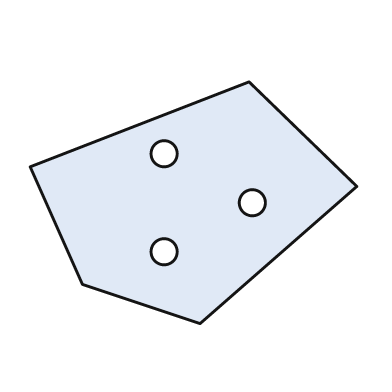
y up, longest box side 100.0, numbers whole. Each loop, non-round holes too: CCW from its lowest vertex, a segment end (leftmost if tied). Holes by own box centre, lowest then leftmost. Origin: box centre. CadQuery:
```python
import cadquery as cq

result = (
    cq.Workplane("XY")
    .moveTo(2.0, -37.0)
    .lineTo(50.0, 5.0)
    .lineTo(17.0, 37.0)
    .lineTo(-50.0, 11.0)
    .lineTo(-34.0, -25.0)
    .close()
    .moveTo(-9.0, -15.0)
    .circle(4.0)
    .moveTo(18.0, 0.0)
    .circle(4.0)
    .moveTo(-9.0, 15.0)
    .circle(4.0)
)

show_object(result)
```